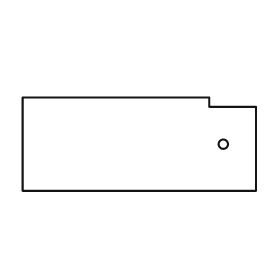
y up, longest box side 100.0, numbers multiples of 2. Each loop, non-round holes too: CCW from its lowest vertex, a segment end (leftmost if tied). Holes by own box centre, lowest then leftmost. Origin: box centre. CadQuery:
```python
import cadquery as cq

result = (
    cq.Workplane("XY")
    .moveTo(-50.0, -20.0)
    .lineTo(50.0, -20.0)
    .lineTo(50.0, 16.0)
    .lineTo(30.0, 16.0)
    .lineTo(30.0, 20.0)
    .lineTo(-50.0, 20.0)
    .close()
    .moveTo(36.0, 0.0)
    .circle(2.0)
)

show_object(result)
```